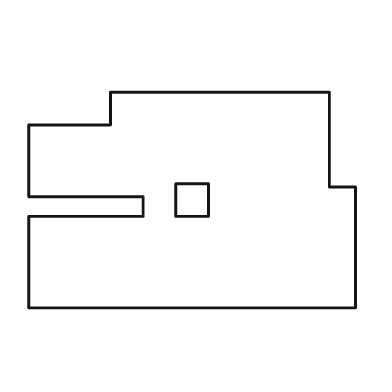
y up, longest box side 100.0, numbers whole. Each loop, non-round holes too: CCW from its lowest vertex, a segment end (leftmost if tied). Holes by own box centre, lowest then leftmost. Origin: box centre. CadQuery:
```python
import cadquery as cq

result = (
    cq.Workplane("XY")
    .moveTo(-50.0, -33.0)
    .lineTo(50.0, -33.0)
    .lineTo(50.0, 4.0)
    .lineTo(42.0, 4.0)
    .lineTo(42.0, 33.0)
    .lineTo(-25.0, 33.0)
    .lineTo(-25.0, 23.0)
    .lineTo(-50.0, 23.0)
    .lineTo(-50.0, 1.0)
    .lineTo(-15.0, 1.0)
    .lineTo(-15.0, -5.0)
    .lineTo(-50.0, -5.0)
    .close()
    .moveTo(-5.0, -5.0)
    .lineTo(5.0, -5.0)
    .lineTo(5.0, 5.0)
    .lineTo(-5.0, 5.0)
    .close()
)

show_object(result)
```